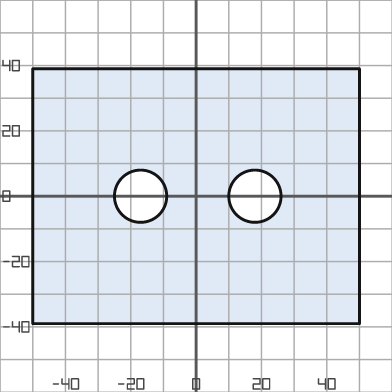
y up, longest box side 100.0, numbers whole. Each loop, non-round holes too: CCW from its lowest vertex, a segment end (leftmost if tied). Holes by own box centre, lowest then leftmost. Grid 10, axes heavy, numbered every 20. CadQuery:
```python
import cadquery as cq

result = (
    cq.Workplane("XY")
    .moveTo(-50.0, -39.0)
    .lineTo(50.0, -39.0)
    .lineTo(50.0, 39.0)
    .lineTo(-50.0, 39.0)
    .close()
    .moveTo(-17.0, 0.0)
    .circle(8.0)
    .moveTo(18.0, 0.0)
    .circle(8.0)
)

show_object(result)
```